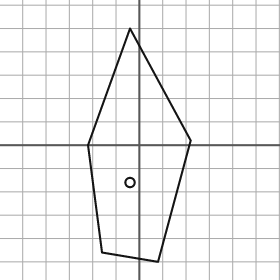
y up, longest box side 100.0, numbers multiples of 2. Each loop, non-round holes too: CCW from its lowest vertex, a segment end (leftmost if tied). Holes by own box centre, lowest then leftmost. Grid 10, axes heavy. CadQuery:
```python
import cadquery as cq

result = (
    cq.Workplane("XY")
    .moveTo(8.0, -50.0)
    .lineTo(22.0, 2.0)
    .lineTo(-4.0, 50.0)
    .lineTo(-22.0, 0.0)
    .lineTo(-16.0, -46.0)
    .close()
    .moveTo(-4.0, -16.0)
    .circle(2.0)
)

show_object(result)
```